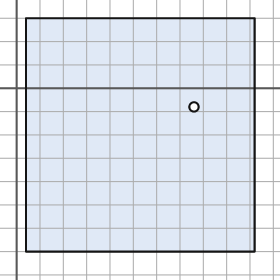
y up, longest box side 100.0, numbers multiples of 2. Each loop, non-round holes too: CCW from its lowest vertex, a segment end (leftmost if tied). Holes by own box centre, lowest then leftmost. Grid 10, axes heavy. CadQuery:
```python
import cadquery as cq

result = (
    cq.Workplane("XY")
    .moveTo(4.0, -70.0)
    .lineTo(102.0, -70.0)
    .lineTo(102.0, 30.0)
    .lineTo(4.0, 30.0)
    .close()
    .moveTo(76.0, -8.0)
    .circle(2.0)
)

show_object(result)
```